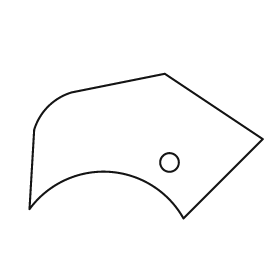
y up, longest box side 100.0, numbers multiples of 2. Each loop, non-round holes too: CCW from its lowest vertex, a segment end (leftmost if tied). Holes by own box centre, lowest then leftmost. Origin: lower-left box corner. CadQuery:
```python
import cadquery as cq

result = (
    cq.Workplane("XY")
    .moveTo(66.0, 0.0)
    .lineTo(100.0, 34.0)
    .lineTo(58.0, 62.0)
    .lineTo(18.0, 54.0)
    .threePointArc((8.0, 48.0), (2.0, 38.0))
    .lineTo(0.0, 4.0)
    .threePointArc((34.0, 20.0), (66.0, 0.0))
    .close()
    .moveTo(60.0, 24.0)
    .circle(4.0)
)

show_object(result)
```